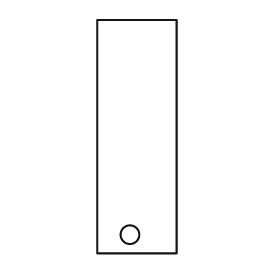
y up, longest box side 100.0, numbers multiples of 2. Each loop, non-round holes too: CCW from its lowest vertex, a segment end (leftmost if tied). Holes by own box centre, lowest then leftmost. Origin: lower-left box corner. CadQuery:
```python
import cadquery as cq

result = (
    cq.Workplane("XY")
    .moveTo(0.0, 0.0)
    .lineTo(34.0, 0.0)
    .lineTo(34.0, 100.0)
    .lineTo(0.0, 100.0)
    .close()
    .moveTo(14.0, 8.0)
    .circle(4.0)
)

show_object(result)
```